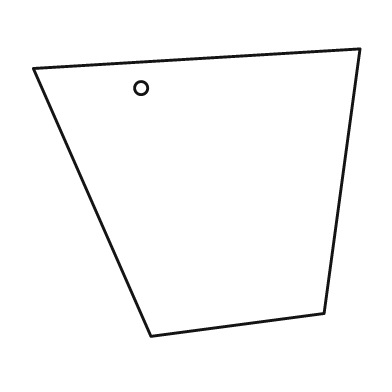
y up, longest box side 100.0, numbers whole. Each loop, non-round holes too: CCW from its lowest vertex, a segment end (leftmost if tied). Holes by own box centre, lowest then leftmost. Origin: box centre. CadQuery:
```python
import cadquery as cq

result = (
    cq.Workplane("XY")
    .moveTo(-14.0, -44.0)
    .lineTo(39.0, -37.0)
    .lineTo(50.0, 44.0)
    .lineTo(-50.0, 38.0)
    .close()
    .moveTo(-17.0, 32.0)
    .circle(2.0)
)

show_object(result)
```